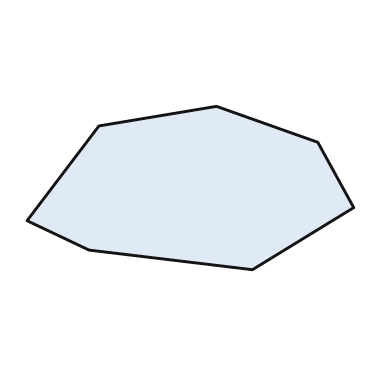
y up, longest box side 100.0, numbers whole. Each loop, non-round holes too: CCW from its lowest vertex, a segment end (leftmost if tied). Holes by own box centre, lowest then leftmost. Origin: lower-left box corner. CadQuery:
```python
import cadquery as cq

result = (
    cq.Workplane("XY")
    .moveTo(69.0, 0.0)
    .lineTo(100.0, 19.0)
    .lineTo(89.0, 39.0)
    .lineTo(58.0, 50.0)
    .lineTo(22.0, 44.0)
    .lineTo(0.0, 15.0)
    .lineTo(19.0, 6.0)
    .close()
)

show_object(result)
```